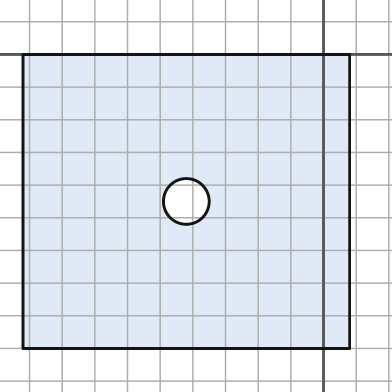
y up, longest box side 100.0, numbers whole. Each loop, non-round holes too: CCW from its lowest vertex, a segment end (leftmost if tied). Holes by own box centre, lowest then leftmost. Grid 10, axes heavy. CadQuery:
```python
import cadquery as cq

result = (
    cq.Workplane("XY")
    .moveTo(-92.0, -90.0)
    .lineTo(8.0, -90.0)
    .lineTo(8.0, 0.0)
    .lineTo(-92.0, 0.0)
    .close()
    .moveTo(-42.0, -45.0)
    .circle(7.0)
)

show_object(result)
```